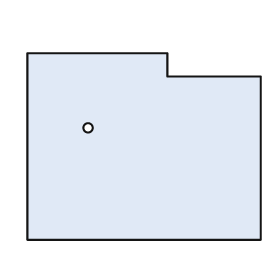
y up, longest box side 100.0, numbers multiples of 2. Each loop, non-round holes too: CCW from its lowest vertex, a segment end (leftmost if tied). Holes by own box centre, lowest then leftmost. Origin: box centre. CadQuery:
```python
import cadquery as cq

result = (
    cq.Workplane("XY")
    .moveTo(-50.0, -40.0)
    .lineTo(50.0, -40.0)
    .lineTo(50.0, 30.0)
    .lineTo(10.0, 30.0)
    .lineTo(10.0, 40.0)
    .lineTo(-50.0, 40.0)
    .close()
    .moveTo(-24.0, 8.0)
    .circle(2.0)
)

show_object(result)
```